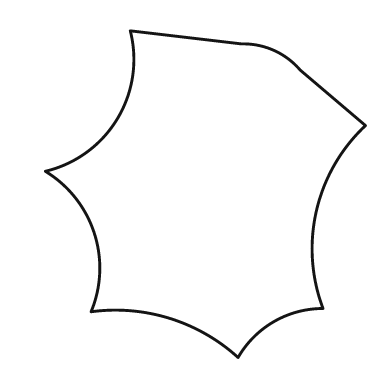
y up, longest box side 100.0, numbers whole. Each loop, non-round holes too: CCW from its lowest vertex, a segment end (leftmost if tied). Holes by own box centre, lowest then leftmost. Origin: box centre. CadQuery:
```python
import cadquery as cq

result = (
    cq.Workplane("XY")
    .moveTo(10.0, -50.0)
    .threePointArc((21.0, -39.0), (36.0, -35.0))
    .threePointArc((34.0, -5.0), (49.0, 21.0))
    .lineTo(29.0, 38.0)
    .threePointArc((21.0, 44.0), (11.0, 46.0))
    .lineTo(-23.0, 50.0)
    .threePointArc((-27.0, 23.0), (-49.0, 7.0))
    .threePointArc((-34.0, -12.0), (-35.0, -36.0))
    .threePointArc((-11.0, -38.0), (10.0, -50.0))
    .close()
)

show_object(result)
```